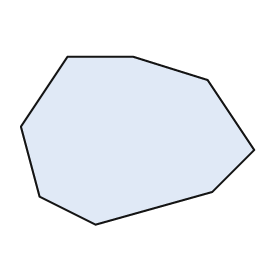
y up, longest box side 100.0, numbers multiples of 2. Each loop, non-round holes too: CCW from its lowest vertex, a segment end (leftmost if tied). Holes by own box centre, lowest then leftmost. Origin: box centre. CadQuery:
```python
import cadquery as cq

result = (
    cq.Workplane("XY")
    .moveTo(-18.0, -36.0)
    .lineTo(32.0, -22.0)
    .lineTo(50.0, -4.0)
    .lineTo(30.0, 26.0)
    .lineTo(-2.0, 36.0)
    .lineTo(-30.0, 36.0)
    .lineTo(-50.0, 6.0)
    .lineTo(-42.0, -24.0)
    .close()
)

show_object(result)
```